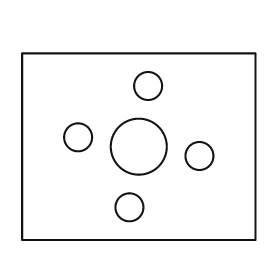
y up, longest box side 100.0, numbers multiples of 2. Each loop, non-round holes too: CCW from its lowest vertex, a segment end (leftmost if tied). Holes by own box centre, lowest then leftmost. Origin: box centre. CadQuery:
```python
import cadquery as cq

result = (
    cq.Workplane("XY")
    .moveTo(-50.0, -40.0)
    .lineTo(50.0, -40.0)
    .lineTo(50.0, 40.0)
    .lineTo(-50.0, 40.0)
    .close()
    .moveTo(-4.0, -26.0)
    .circle(6.0)
    .moveTo(26.0, -4.0)
    .circle(6.0)
    .moveTo(0.0, 0.0)
    .circle(12.0)
    .moveTo(-26.0, 4.0)
    .circle(6.0)
    .moveTo(4.0, 26.0)
    .circle(6.0)
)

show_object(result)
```